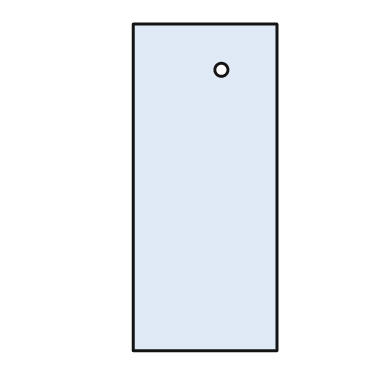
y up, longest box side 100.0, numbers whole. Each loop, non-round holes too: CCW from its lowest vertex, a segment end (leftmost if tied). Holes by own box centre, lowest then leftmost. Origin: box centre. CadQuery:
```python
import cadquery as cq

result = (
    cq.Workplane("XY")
    .moveTo(-22.0, -50.0)
    .lineTo(22.0, -50.0)
    .lineTo(22.0, 50.0)
    .lineTo(-22.0, 50.0)
    .close()
    .moveTo(5.0, 36.0)
    .circle(2.0)
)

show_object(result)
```